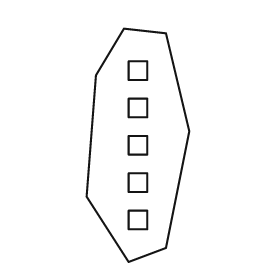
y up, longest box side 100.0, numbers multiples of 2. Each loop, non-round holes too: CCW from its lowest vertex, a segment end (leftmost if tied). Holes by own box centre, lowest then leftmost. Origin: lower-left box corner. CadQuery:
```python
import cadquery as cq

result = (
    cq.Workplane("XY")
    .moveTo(18.0, 0.0)
    .lineTo(34.0, 6.0)
    .lineTo(44.0, 56.0)
    .lineTo(34.0, 98.0)
    .lineTo(16.0, 100.0)
    .lineTo(4.0, 80.0)
    .lineTo(0.0, 28.0)
    .close()
    .moveTo(18.0, 14.0)
    .lineTo(26.0, 14.0)
    .lineTo(26.0, 22.0)
    .lineTo(18.0, 22.0)
    .close()
    .moveTo(18.0, 30.0)
    .lineTo(26.0, 30.0)
    .lineTo(26.0, 38.0)
    .lineTo(18.0, 38.0)
    .close()
    .moveTo(18.0, 46.0)
    .lineTo(26.0, 46.0)
    .lineTo(26.0, 54.0)
    .lineTo(18.0, 54.0)
    .close()
    .moveTo(18.0, 62.0)
    .lineTo(26.0, 62.0)
    .lineTo(26.0, 70.0)
    .lineTo(18.0, 70.0)
    .close()
    .moveTo(18.0, 78.0)
    .lineTo(26.0, 78.0)
    .lineTo(26.0, 86.0)
    .lineTo(18.0, 86.0)
    .close()
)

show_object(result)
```